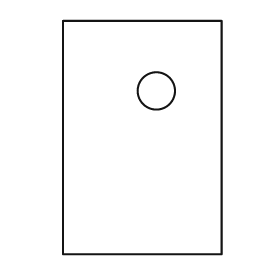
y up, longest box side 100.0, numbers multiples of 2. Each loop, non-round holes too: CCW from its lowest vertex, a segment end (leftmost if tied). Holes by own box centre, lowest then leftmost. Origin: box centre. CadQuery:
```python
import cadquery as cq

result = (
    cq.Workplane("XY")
    .moveTo(-34.0, -50.0)
    .lineTo(34.0, -50.0)
    .lineTo(34.0, 50.0)
    .lineTo(-34.0, 50.0)
    .close()
    .moveTo(6.0, 20.0)
    .circle(8.0)
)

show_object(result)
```